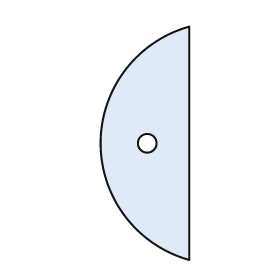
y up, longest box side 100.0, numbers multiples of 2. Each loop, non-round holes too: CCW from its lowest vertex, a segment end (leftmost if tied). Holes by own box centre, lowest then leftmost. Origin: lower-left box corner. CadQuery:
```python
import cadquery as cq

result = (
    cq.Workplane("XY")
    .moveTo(38.0, 0.0)
    .lineTo(38.0, 100.0)
    .threePointArc((0.0, 50.0), (38.0, 0.0))
    .close()
    .moveTo(20.0, 50.0)
    .circle(4.0)
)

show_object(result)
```